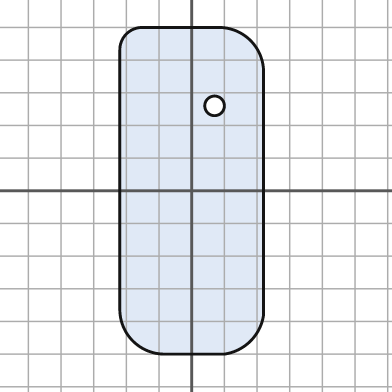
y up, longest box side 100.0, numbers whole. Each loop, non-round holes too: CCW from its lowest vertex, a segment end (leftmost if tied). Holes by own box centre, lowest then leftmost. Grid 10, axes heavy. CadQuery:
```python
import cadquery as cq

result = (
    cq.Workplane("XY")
    .moveTo(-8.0, -50.0)
    .lineTo(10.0, -50.0)
    .threePointArc((18.0, -46.0), (22.0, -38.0))
    .lineTo(22.0, 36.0)
    .threePointArc((18.0, 46.0), (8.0, 50.0))
    .lineTo(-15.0, 50.0)
    .threePointArc((-20.0, 48.0), (-22.0, 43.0))
    .lineTo(-22.0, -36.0)
    .threePointArc((-18.0, -46.0), (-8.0, -50.0))
    .close()
    .moveTo(7.0, 26.0)
    .circle(3.0)
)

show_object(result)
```